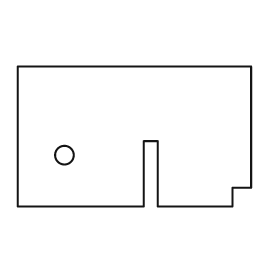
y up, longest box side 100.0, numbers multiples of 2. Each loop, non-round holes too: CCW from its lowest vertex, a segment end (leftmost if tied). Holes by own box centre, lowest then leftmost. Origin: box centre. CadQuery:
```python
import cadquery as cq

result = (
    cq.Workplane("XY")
    .moveTo(-50.0, -30.0)
    .lineTo(4.0, -30.0)
    .lineTo(4.0, -2.0)
    .lineTo(10.0, -2.0)
    .lineTo(10.0, -30.0)
    .lineTo(42.0, -30.0)
    .lineTo(42.0, -22.0)
    .lineTo(50.0, -22.0)
    .lineTo(50.0, 30.0)
    .lineTo(-50.0, 30.0)
    .close()
    .moveTo(-30.0, -8.0)
    .circle(4.0)
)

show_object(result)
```